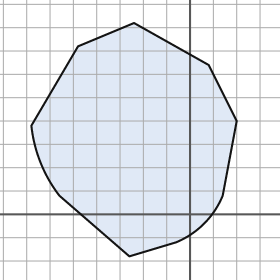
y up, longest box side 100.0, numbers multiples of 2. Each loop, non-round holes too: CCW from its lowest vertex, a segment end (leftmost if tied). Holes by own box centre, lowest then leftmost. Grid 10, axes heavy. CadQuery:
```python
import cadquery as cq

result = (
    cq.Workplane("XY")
    .moveTo(-26.0, -18.0)
    .lineTo(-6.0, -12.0)
    .threePointArc((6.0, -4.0), (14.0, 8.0))
    .lineTo(20.0, 40.0)
    .lineTo(8.0, 64.0)
    .lineTo(-24.0, 82.0)
    .lineTo(-48.0, 72.0)
    .lineTo(-68.0, 38.0)
    .threePointArc((-64.0, 22.0), (-56.0, 8.0))
    .close()
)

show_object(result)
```